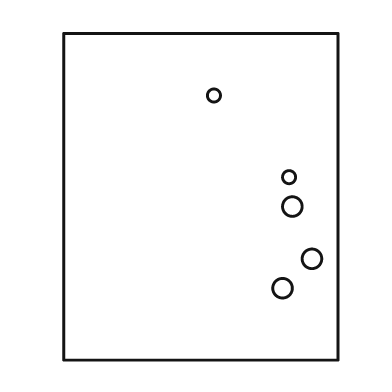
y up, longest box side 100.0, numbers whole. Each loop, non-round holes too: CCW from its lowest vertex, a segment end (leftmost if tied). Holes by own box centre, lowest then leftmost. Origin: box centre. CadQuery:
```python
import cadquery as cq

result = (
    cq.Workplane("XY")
    .moveTo(-42.0, -50.0)
    .lineTo(42.0, -50.0)
    .lineTo(42.0, 50.0)
    .lineTo(-42.0, 50.0)
    .close()
    .moveTo(25.0, -28.0)
    .circle(3.0)
    .moveTo(34.0, -19.0)
    .circle(3.0)
    .moveTo(28.0, -3.0)
    .circle(3.0)
    .moveTo(27.0, 6.0)
    .circle(2.0)
    .moveTo(4.0, 31.0)
    .circle(2.0)
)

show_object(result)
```